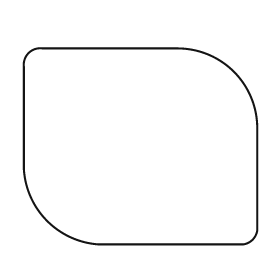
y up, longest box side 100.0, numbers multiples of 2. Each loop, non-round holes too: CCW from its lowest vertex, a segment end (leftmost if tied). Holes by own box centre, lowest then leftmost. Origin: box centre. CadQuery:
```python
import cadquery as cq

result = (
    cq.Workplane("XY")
    .moveTo(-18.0, -42.0)
    .lineTo(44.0, -42.0)
    .threePointArc((48.0, -40.0), (50.0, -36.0))
    .lineTo(50.0, 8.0)
    .threePointArc((40.0, 32.0), (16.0, 42.0))
    .lineTo(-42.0, 42.0)
    .threePointArc((-48.0, 40.0), (-50.0, 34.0))
    .lineTo(-50.0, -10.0)
    .threePointArc((-40.0, -32.0), (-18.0, -42.0))
    .close()
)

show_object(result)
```